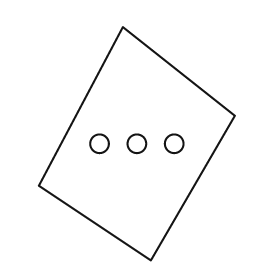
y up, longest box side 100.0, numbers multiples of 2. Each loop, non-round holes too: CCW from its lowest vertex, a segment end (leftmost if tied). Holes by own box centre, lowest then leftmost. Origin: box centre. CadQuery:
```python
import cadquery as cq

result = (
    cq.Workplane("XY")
    .moveTo(6.0, -50.0)
    .lineTo(42.0, 12.0)
    .lineTo(-6.0, 50.0)
    .lineTo(-42.0, -18.0)
    .close()
    .moveTo(-16.0, 0.0)
    .circle(4.0)
    .moveTo(0.0, 0.0)
    .circle(4.0)
    .moveTo(16.0, 0.0)
    .circle(4.0)
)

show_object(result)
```